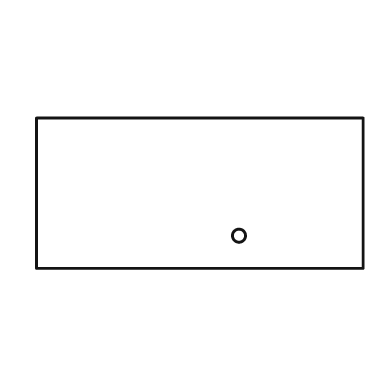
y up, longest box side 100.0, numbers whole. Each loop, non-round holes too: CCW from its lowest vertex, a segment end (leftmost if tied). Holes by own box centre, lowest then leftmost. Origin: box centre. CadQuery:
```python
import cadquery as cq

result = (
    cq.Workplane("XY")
    .moveTo(-50.0, -23.0)
    .lineTo(50.0, -23.0)
    .lineTo(50.0, 23.0)
    .lineTo(-50.0, 23.0)
    .close()
    .moveTo(12.0, -13.0)
    .circle(2.0)
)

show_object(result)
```